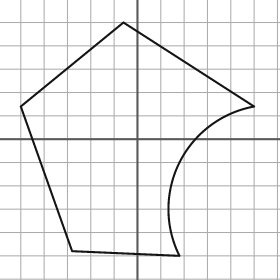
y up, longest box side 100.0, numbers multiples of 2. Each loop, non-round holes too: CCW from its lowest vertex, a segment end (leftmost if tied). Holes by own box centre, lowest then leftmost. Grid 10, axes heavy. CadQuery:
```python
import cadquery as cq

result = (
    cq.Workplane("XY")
    .moveTo(18.0, -50.0)
    .threePointArc((18.0, -10.0), (50.0, 14.0))
    .lineTo(-6.0, 50.0)
    .lineTo(-50.0, 14.0)
    .lineTo(-28.0, -48.0)
    .close()
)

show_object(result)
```